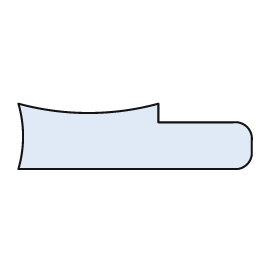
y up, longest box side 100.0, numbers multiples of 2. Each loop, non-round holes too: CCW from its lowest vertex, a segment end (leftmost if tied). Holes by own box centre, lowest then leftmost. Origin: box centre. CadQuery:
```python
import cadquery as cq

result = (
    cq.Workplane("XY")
    .moveTo(-50.0, -14.0)
    .lineTo(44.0, -14.0)
    .threePointArc((48.0, -12.0), (50.0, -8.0))
    .lineTo(50.0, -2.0)
    .threePointArc((48.0, 4.0), (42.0, 6.0))
    .lineTo(10.0, 6.0)
    .lineTo(10.0, 14.0)
    .threePointArc((-20.0, 10.0), (-50.0, 14.0))
    .threePointArc((-48.0, 0.0), (-50.0, -14.0))
    .close()
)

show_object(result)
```